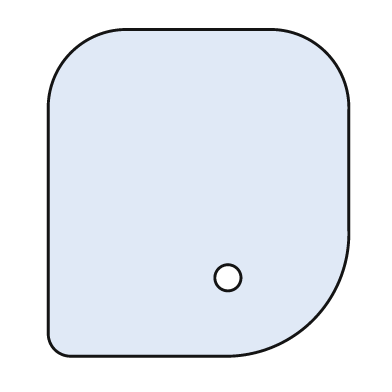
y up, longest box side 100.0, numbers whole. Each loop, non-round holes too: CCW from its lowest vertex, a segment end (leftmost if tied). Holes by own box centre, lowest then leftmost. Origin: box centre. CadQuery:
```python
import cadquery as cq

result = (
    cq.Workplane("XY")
    .moveTo(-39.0, -50.0)
    .lineTo(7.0, -50.0)
    .threePointArc((35.0, -39.0), (46.0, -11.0))
    .lineTo(46.0, 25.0)
    .threePointArc((39.0, 43.0), (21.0, 50.0))
    .lineTo(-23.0, 50.0)
    .threePointArc((-39.0, 43.0), (-46.0, 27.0))
    .lineTo(-46.0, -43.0)
    .threePointArc((-44.0, -48.0), (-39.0, -50.0))
    .close()
    .moveTo(9.0, -26.0)
    .circle(4.0)
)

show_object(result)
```